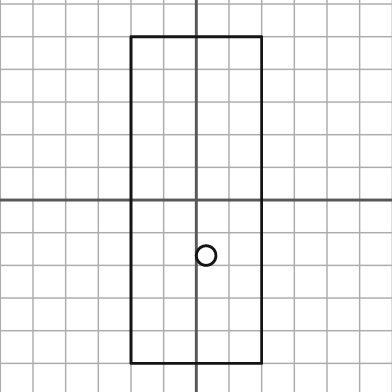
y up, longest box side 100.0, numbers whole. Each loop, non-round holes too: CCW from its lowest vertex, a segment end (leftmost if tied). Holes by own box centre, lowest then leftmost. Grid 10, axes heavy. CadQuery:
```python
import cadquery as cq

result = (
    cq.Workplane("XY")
    .moveTo(-20.0, -50.0)
    .lineTo(20.0, -50.0)
    .lineTo(20.0, 50.0)
    .lineTo(-20.0, 50.0)
    .close()
    .moveTo(3.0, -17.0)
    .circle(3.0)
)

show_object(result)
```